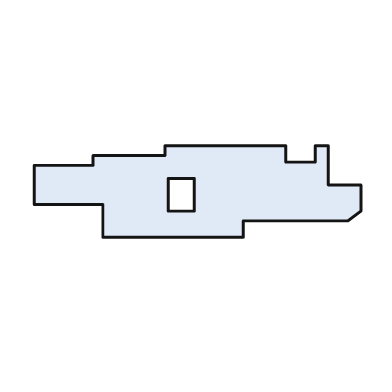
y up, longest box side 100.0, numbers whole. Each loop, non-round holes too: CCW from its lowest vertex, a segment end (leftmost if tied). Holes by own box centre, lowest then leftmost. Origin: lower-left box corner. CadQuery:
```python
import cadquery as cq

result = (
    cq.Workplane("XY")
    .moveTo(21.0, 0.0)
    .lineTo(64.0, 0.0)
    .lineTo(64.0, 5.0)
    .lineTo(96.0, 5.0)
    .lineTo(100.0, 8.0)
    .lineTo(100.0, 16.0)
    .lineTo(90.0, 16.0)
    .lineTo(90.0, 28.0)
    .lineTo(86.0, 28.0)
    .lineTo(86.0, 23.0)
    .lineTo(77.0, 23.0)
    .lineTo(77.0, 28.0)
    .lineTo(40.0, 28.0)
    .lineTo(40.0, 25.0)
    .lineTo(18.0, 25.0)
    .lineTo(18.0, 22.0)
    .lineTo(0.0, 22.0)
    .lineTo(0.0, 10.0)
    .lineTo(21.0, 10.0)
    .close()
    .moveTo(41.0, 8.0)
    .lineTo(49.0, 8.0)
    .lineTo(49.0, 18.0)
    .lineTo(41.0, 18.0)
    .close()
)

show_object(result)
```